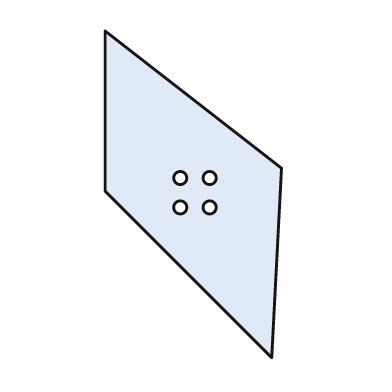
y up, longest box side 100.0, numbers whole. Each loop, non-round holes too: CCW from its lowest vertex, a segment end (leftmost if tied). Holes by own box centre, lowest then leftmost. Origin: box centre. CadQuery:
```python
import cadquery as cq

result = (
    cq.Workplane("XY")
    .moveTo(24.0, -50.0)
    .lineTo(27.0, 8.0)
    .lineTo(-27.0, 50.0)
    .lineTo(-27.0, 1.0)
    .close()
    .moveTo(-4.0, -4.0)
    .circle(2.0)
    .moveTo(5.0, -4.0)
    .circle(2.0)
    .moveTo(-4.0, 5.0)
    .circle(2.0)
    .moveTo(5.0, 5.0)
    .circle(2.0)
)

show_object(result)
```